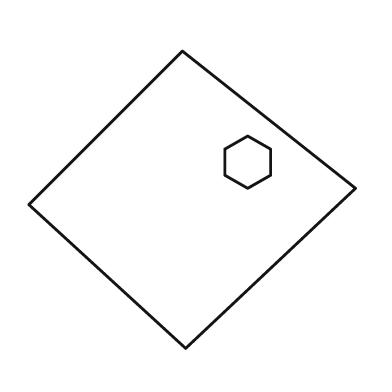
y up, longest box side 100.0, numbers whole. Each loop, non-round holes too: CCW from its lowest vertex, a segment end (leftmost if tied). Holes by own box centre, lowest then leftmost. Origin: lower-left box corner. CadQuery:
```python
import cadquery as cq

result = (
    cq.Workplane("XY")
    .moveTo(48.0, 0.0)
    .lineTo(100.0, 49.0)
    .lineTo(47.0, 91.0)
    .lineTo(0.0, 44.0)
    .close()
    .moveTo(67.0, 49.0)
    .lineTo(74.0, 53.0)
    .lineTo(74.0, 61.0)
    .lineTo(67.0, 65.0)
    .lineTo(60.0, 61.0)
    .lineTo(60.0, 53.0)
    .close()
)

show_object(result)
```